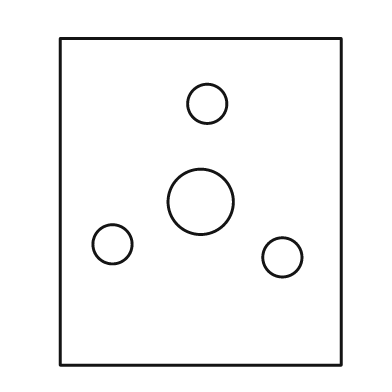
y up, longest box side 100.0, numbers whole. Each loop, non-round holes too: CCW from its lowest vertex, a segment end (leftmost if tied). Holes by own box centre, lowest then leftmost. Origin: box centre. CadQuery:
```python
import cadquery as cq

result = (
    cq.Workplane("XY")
    .moveTo(-43.0, -50.0)
    .lineTo(43.0, -50.0)
    .lineTo(43.0, 50.0)
    .lineTo(-43.0, 50.0)
    .close()
    .moveTo(25.0, -17.0)
    .circle(6.0)
    .moveTo(-27.0, -13.0)
    .circle(6.0)
    .moveTo(0.0, 0.0)
    .circle(10.0)
    .moveTo(2.0, 30.0)
    .circle(6.0)
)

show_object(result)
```